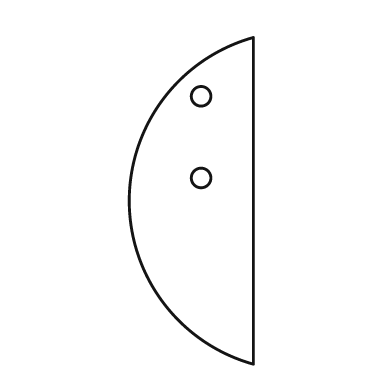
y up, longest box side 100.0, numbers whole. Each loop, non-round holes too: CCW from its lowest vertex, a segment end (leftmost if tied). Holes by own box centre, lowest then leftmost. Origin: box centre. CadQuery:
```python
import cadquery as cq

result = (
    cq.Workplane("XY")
    .moveTo(19.0, -50.0)
    .lineTo(19.0, 50.0)
    .threePointArc((-19.0, 0.0), (19.0, -50.0))
    .close()
    .moveTo(3.0, 7.0)
    .circle(3.0)
    .moveTo(3.0, 32.0)
    .circle(3.0)
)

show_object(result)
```